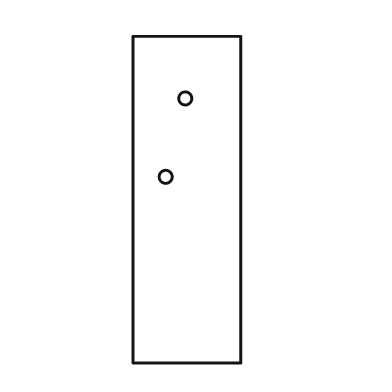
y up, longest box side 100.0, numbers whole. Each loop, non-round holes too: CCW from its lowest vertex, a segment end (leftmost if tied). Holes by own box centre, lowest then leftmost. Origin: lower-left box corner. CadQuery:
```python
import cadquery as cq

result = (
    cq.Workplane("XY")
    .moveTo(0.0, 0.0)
    .lineTo(33.0, 0.0)
    .lineTo(33.0, 100.0)
    .lineTo(0.0, 100.0)
    .close()
    .moveTo(10.0, 57.0)
    .circle(2.0)
    .moveTo(16.0, 81.0)
    .circle(2.0)
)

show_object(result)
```